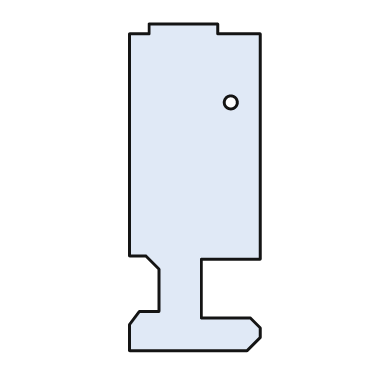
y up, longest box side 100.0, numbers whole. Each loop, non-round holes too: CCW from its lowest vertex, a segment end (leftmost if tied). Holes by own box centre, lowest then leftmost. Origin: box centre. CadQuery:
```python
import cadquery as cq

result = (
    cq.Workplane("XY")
    .moveTo(-20.0, -50.0)
    .lineTo(16.0, -50.0)
    .lineTo(20.0, -46.0)
    .lineTo(20.0, -43.0)
    .lineTo(17.0, -40.0)
    .lineTo(2.0, -40.0)
    .lineTo(2.0, -22.0)
    .lineTo(20.0, -22.0)
    .lineTo(20.0, 47.0)
    .lineTo(7.0, 47.0)
    .lineTo(7.0, 50.0)
    .lineTo(-14.0, 50.0)
    .lineTo(-14.0, 47.0)
    .lineTo(-20.0, 47.0)
    .lineTo(-20.0, -21.0)
    .lineTo(-15.0, -21.0)
    .lineTo(-11.0, -25.0)
    .lineTo(-11.0, -38.0)
    .lineTo(-17.0, -38.0)
    .lineTo(-20.0, -42.0)
    .close()
    .moveTo(11.0, 26.0)
    .circle(2.0)
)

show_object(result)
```